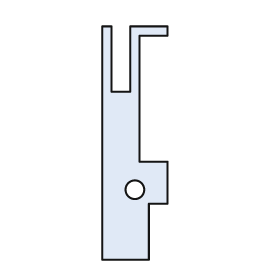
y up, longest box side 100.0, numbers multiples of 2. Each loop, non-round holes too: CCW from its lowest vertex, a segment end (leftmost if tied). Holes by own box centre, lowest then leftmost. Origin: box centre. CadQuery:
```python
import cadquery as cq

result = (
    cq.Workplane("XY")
    .moveTo(-14.0, -50.0)
    .lineTo(6.0, -50.0)
    .lineTo(6.0, -26.0)
    .lineTo(14.0, -26.0)
    .lineTo(14.0, -8.0)
    .lineTo(2.0, -8.0)
    .lineTo(2.0, 46.0)
    .lineTo(14.0, 46.0)
    .lineTo(14.0, 50.0)
    .lineTo(-2.0, 50.0)
    .lineTo(-2.0, 22.0)
    .lineTo(-10.0, 22.0)
    .lineTo(-10.0, 50.0)
    .lineTo(-14.0, 50.0)
    .close()
    .moveTo(0.0, -20.0)
    .circle(4.0)
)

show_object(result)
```